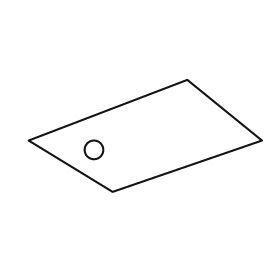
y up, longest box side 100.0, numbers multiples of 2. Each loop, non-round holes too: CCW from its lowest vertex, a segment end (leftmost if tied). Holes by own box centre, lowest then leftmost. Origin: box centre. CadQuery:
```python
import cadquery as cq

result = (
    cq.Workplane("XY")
    .moveTo(-14.0, -24.0)
    .lineTo(50.0, -2.0)
    .lineTo(18.0, 24.0)
    .lineTo(-50.0, -2.0)
    .close()
    .moveTo(-22.0, -6.0)
    .circle(4.0)
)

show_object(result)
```